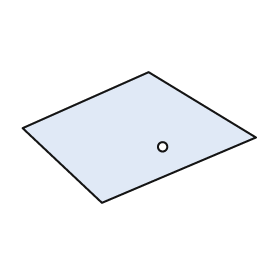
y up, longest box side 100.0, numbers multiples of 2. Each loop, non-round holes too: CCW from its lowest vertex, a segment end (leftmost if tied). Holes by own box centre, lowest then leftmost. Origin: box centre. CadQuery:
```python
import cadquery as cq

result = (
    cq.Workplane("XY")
    .moveTo(-16.0, -28.0)
    .lineTo(50.0, 0.0)
    .lineTo(4.0, 28.0)
    .lineTo(-50.0, 4.0)
    .close()
    .moveTo(10.0, -4.0)
    .circle(2.0)
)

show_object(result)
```